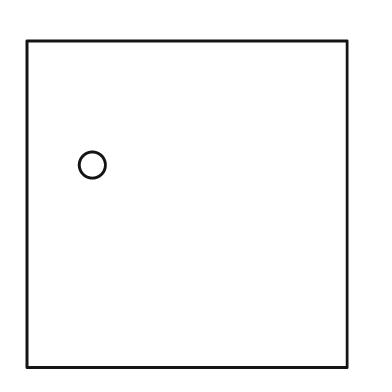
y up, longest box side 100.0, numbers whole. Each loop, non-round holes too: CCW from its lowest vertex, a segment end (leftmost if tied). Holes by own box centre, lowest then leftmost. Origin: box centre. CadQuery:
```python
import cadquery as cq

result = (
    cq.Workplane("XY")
    .moveTo(-49.0, -50.0)
    .lineTo(49.0, -50.0)
    .lineTo(49.0, 50.0)
    .lineTo(-49.0, 50.0)
    .close()
    .moveTo(-29.0, 12.0)
    .circle(4.0)
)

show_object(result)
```